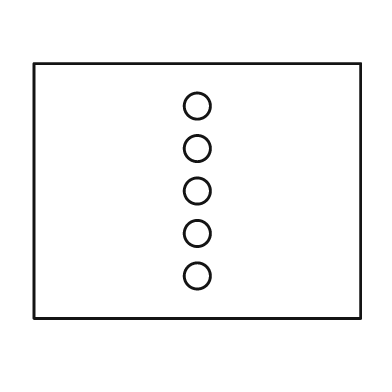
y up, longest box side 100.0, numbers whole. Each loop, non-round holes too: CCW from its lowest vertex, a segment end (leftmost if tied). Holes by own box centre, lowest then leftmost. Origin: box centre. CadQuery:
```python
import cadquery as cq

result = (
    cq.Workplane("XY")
    .moveTo(-50.0, -39.0)
    .lineTo(50.0, -39.0)
    .lineTo(50.0, 39.0)
    .lineTo(-50.0, 39.0)
    .close()
    .moveTo(0.0, -26.0)
    .circle(4.0)
    .moveTo(0.0, -13.0)
    .circle(4.0)
    .moveTo(0.0, 0.0)
    .circle(4.0)
    .moveTo(0.0, 13.0)
    .circle(4.0)
    .moveTo(0.0, 26.0)
    .circle(4.0)
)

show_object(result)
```